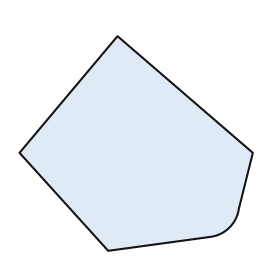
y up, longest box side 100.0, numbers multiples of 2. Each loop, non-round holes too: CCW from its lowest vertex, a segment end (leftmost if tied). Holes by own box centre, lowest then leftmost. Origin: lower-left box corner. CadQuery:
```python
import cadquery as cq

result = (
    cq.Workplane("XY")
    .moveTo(38.0, 0.0)
    .lineTo(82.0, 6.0)
    .threePointArc((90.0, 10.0), (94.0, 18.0))
    .lineTo(100.0, 42.0)
    .lineTo(42.0, 92.0)
    .lineTo(0.0, 42.0)
    .close()
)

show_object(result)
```